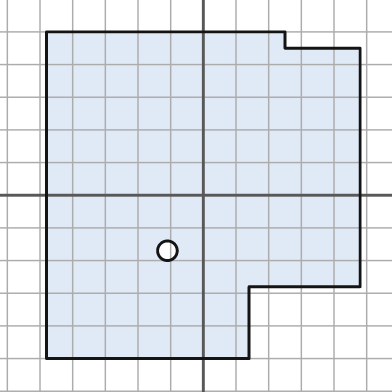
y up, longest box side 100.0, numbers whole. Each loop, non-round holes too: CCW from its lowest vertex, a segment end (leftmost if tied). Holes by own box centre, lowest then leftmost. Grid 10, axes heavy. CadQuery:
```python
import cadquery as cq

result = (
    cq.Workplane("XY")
    .moveTo(-48.0, -50.0)
    .lineTo(14.0, -50.0)
    .lineTo(14.0, -28.0)
    .lineTo(48.0, -28.0)
    .lineTo(48.0, 45.0)
    .lineTo(25.0, 45.0)
    .lineTo(25.0, 50.0)
    .lineTo(-48.0, 50.0)
    .close()
    .moveTo(-11.0, -17.0)
    .circle(3.0)
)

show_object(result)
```